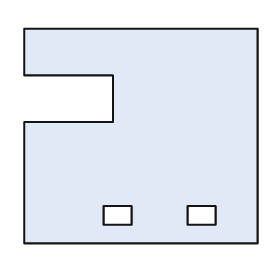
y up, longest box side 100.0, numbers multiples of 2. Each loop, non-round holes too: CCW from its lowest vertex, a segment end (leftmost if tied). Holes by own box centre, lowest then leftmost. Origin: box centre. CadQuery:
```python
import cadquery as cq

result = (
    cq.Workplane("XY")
    .moveTo(-50.0, -46.0)
    .lineTo(50.0, -46.0)
    .lineTo(50.0, 46.0)
    .lineTo(-50.0, 46.0)
    .lineTo(-50.0, 26.0)
    .lineTo(-12.0, 26.0)
    .lineTo(-12.0, 6.0)
    .lineTo(-50.0, 6.0)
    .close()
    .moveTo(-16.0, -38.0)
    .lineTo(-4.0, -38.0)
    .lineTo(-4.0, -30.0)
    .lineTo(-16.0, -30.0)
    .close()
    .moveTo(20.0, -38.0)
    .lineTo(32.0, -38.0)
    .lineTo(32.0, -30.0)
    .lineTo(20.0, -30.0)
    .close()
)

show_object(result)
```